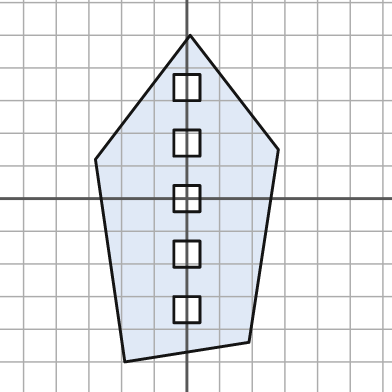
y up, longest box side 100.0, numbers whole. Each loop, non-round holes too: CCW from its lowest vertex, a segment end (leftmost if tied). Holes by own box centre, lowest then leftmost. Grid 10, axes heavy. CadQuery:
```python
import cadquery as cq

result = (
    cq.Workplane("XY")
    .moveTo(-19.0, -50.0)
    .lineTo(19.0, -44.0)
    .lineTo(28.0, 15.0)
    .lineTo(1.0, 50.0)
    .lineTo(-28.0, 12.0)
    .close()
    .moveTo(-4.0, -38.0)
    .lineTo(4.0, -38.0)
    .lineTo(4.0, -30.0)
    .lineTo(-4.0, -30.0)
    .close()
    .moveTo(-4.0, -21.0)
    .lineTo(4.0, -21.0)
    .lineTo(4.0, -13.0)
    .lineTo(-4.0, -13.0)
    .close()
    .moveTo(-4.0, -4.0)
    .lineTo(4.0, -4.0)
    .lineTo(4.0, 4.0)
    .lineTo(-4.0, 4.0)
    .close()
    .moveTo(-4.0, 13.0)
    .lineTo(4.0, 13.0)
    .lineTo(4.0, 21.0)
    .lineTo(-4.0, 21.0)
    .close()
    .moveTo(-4.0, 30.0)
    .lineTo(4.0, 30.0)
    .lineTo(4.0, 38.0)
    .lineTo(-4.0, 38.0)
    .close()
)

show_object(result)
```